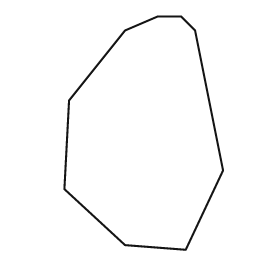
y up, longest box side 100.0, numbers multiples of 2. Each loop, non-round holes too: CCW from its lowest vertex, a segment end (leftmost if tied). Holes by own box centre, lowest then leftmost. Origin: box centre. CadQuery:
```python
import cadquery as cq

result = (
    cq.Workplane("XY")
    .moveTo(18.0, -50.0)
    .lineTo(34.0, -16.0)
    .lineTo(22.0, 44.0)
    .lineTo(16.0, 50.0)
    .lineTo(6.0, 50.0)
    .lineTo(-8.0, 44.0)
    .lineTo(-32.0, 14.0)
    .lineTo(-34.0, -24.0)
    .lineTo(-8.0, -48.0)
    .close()
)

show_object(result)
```